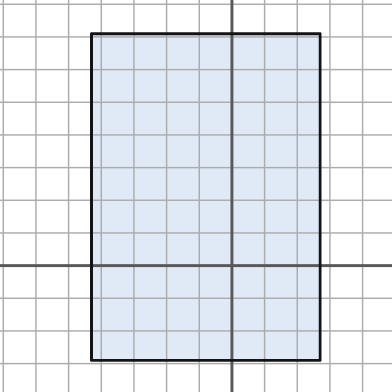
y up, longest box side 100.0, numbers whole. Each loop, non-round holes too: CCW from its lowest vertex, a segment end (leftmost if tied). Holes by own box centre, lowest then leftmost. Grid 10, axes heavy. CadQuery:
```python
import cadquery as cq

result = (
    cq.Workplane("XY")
    .moveTo(-43.0, -29.0)
    .lineTo(27.0, -29.0)
    .lineTo(27.0, 71.0)
    .lineTo(-43.0, 71.0)
    .close()
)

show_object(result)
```